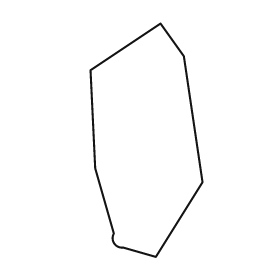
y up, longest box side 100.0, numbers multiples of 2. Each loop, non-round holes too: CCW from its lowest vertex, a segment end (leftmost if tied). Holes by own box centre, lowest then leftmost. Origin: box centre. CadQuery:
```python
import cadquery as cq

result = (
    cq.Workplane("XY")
    .moveTo(4.0, -50.0)
    .lineTo(24.0, -18.0)
    .lineTo(16.0, 36.0)
    .lineTo(6.0, 50.0)
    .lineTo(-24.0, 30.0)
    .lineTo(-22.0, -12.0)
    .lineTo(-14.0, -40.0)
    .threePointArc((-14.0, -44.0), (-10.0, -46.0))
    .close()
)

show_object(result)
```